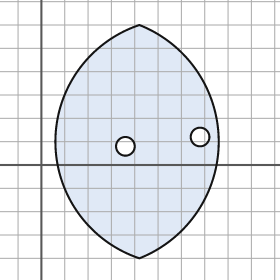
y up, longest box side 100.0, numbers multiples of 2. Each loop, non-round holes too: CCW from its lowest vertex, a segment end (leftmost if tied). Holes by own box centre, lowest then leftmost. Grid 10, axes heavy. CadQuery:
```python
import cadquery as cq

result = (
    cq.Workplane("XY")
    .moveTo(42.0, -40.0)
    .threePointArc((76.0, 10.0), (42.0, 60.0))
    .threePointArc((6.0, 10.0), (42.0, -40.0))
    .close()
    .moveTo(36.0, 8.0)
    .circle(4.0)
    .moveTo(68.0, 12.0)
    .circle(4.0)
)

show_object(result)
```